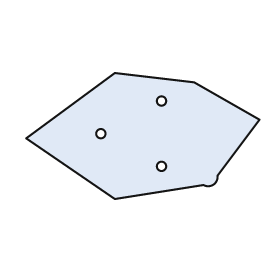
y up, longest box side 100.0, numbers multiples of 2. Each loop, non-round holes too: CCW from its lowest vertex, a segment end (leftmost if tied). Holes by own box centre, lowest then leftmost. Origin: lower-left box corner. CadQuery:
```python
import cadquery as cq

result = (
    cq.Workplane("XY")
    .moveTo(38.0, 0.0)
    .lineTo(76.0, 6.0)
    .threePointArc((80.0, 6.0), (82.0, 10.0))
    .lineTo(100.0, 34.0)
    .lineTo(72.0, 50.0)
    .lineTo(38.0, 54.0)
    .lineTo(0.0, 26.0)
    .close()
    .moveTo(58.0, 14.0)
    .circle(2.0)
    .moveTo(32.0, 28.0)
    .circle(2.0)
    .moveTo(58.0, 42.0)
    .circle(2.0)
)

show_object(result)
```